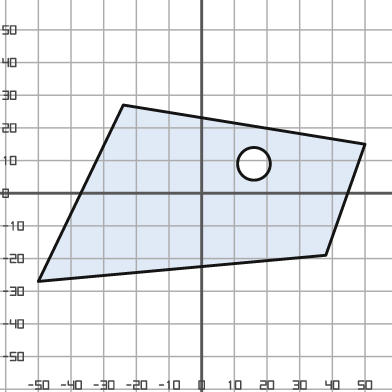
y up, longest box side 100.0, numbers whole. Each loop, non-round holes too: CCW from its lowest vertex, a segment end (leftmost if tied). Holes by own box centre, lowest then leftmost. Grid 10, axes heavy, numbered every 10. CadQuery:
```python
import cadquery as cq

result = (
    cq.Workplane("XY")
    .moveTo(-50.0, -27.0)
    .lineTo(38.0, -19.0)
    .lineTo(50.0, 15.0)
    .lineTo(-24.0, 27.0)
    .close()
    .moveTo(16.0, 9.0)
    .circle(5.0)
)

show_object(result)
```